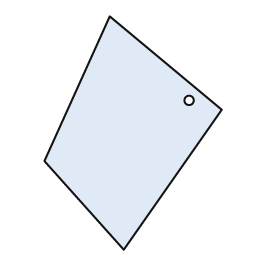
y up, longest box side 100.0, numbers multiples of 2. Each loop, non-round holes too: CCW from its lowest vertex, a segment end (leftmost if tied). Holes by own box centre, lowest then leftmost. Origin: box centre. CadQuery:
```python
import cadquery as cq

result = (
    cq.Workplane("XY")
    .moveTo(-4.0, -50.0)
    .lineTo(38.0, 10.0)
    .lineTo(-10.0, 50.0)
    .lineTo(-38.0, -12.0)
    .close()
    .moveTo(24.0, 14.0)
    .circle(2.0)
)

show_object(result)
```